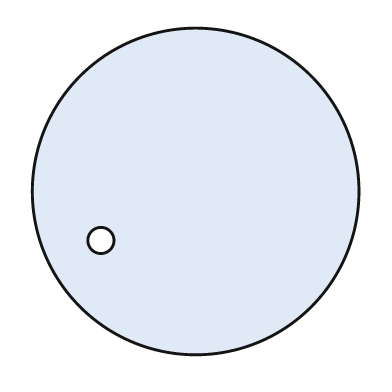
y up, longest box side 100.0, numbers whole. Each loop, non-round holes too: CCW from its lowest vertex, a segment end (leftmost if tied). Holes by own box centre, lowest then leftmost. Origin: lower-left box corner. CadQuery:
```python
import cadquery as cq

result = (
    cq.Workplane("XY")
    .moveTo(50.0, 50.0)
    .circle(50.0)
    .moveTo(21.0, 35.0)
    .circle(4.0)
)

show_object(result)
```